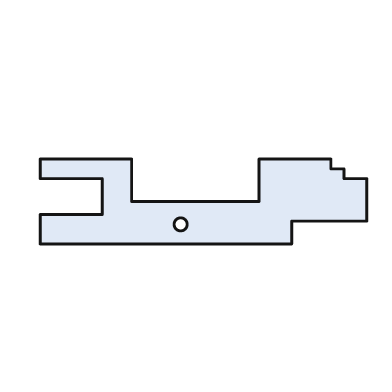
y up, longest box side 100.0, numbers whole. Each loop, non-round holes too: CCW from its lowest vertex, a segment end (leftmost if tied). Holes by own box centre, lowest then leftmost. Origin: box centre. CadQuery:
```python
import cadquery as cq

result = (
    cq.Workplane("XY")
    .moveTo(-50.0, -13.0)
    .lineTo(27.0, -13.0)
    .lineTo(27.0, -6.0)
    .lineTo(50.0, -6.0)
    .lineTo(50.0, 7.0)
    .lineTo(43.0, 7.0)
    .lineTo(43.0, 10.0)
    .lineTo(39.0, 10.0)
    .lineTo(39.0, 13.0)
    .lineTo(17.0, 13.0)
    .lineTo(17.0, 0.0)
    .lineTo(-22.0, 0.0)
    .lineTo(-22.0, 13.0)
    .lineTo(-50.0, 13.0)
    .lineTo(-50.0, 7.0)
    .lineTo(-31.0, 7.0)
    .lineTo(-31.0, -4.0)
    .lineTo(-50.0, -4.0)
    .close()
    .moveTo(-7.0, -7.0)
    .circle(2.0)
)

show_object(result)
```